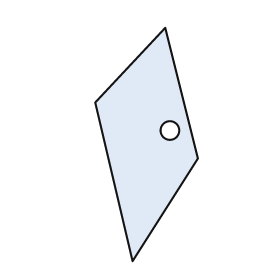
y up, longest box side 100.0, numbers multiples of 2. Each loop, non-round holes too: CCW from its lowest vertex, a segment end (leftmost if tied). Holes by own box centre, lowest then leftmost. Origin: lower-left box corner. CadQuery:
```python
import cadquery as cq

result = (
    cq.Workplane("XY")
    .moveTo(16.0, 0.0)
    .lineTo(44.0, 44.0)
    .lineTo(30.0, 100.0)
    .lineTo(0.0, 68.0)
    .close()
    .moveTo(32.0, 56.0)
    .circle(4.0)
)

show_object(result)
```